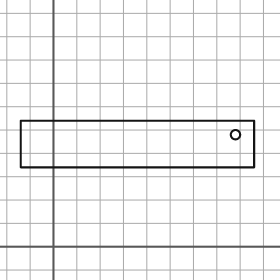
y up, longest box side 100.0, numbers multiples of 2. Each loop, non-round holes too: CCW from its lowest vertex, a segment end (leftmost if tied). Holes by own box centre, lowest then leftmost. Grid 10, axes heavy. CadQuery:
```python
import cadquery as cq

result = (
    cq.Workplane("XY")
    .moveTo(-14.0, 34.0)
    .lineTo(86.0, 34.0)
    .lineTo(86.0, 54.0)
    .lineTo(-14.0, 54.0)
    .close()
    .moveTo(78.0, 48.0)
    .circle(2.0)
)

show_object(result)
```